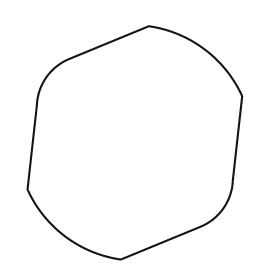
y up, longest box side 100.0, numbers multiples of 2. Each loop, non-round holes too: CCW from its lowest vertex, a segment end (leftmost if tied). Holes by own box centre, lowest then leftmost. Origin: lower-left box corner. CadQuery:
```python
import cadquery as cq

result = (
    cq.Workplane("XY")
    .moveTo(40.0, 0.0)
    .lineTo(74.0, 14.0)
    .threePointArc((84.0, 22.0), (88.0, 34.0))
    .lineTo(92.0, 70.0)
    .threePointArc((76.0, 90.0), (52.0, 100.0))
    .lineTo(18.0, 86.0)
    .threePointArc((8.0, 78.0), (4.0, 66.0))
    .lineTo(0.0, 30.0)
    .threePointArc((16.0, 10.0), (40.0, 0.0))
    .close()
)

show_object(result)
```